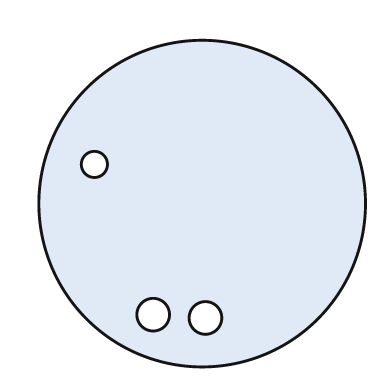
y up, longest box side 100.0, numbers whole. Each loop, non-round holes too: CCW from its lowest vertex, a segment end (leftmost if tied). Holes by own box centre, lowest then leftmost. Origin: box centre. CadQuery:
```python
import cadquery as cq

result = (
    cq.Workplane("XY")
    .moveTo(0.0, 0.0)
    .circle(50.0)
    .moveTo(1.0, -35.0)
    .circle(5.0)
    .moveTo(-15.0, -34.0)
    .circle(5.0)
    .moveTo(-33.0, 12.0)
    .circle(4.0)
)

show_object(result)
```